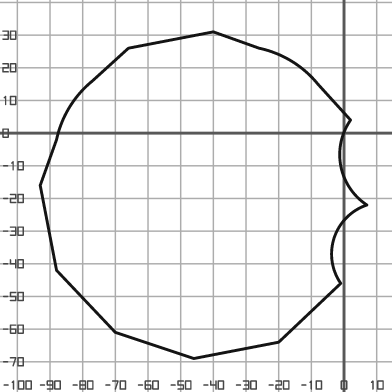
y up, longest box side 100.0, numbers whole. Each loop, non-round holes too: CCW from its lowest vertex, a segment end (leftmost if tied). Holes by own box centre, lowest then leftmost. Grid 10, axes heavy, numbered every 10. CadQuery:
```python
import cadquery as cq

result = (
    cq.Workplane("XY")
    .moveTo(-46.0, -69.0)
    .lineTo(-20.0, -64.0)
    .lineTo(-1.0, -46.0)
    .threePointArc((-3.0, -32.0), (7.0, -22.0))
    .threePointArc((-1.0, -10.0), (2.0, 4.0))
    .lineTo(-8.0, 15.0)
    .threePointArc((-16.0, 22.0), (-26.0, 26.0))
    .lineTo(-40.0, 31.0)
    .lineTo(-66.0, 26.0)
    .lineTo(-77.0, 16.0)
    .threePointArc((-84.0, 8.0), (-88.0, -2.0))
    .lineTo(-93.0, -16.0)
    .lineTo(-88.0, -42.0)
    .lineTo(-70.0, -61.0)
    .close()
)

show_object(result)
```